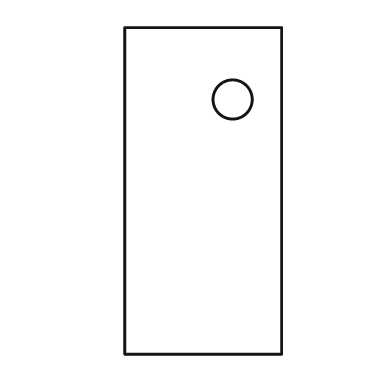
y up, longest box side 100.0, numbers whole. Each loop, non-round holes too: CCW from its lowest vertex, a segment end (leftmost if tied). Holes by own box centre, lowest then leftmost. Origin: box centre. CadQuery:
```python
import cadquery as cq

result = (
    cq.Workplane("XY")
    .moveTo(-24.0, -50.0)
    .lineTo(24.0, -50.0)
    .lineTo(24.0, 50.0)
    .lineTo(-24.0, 50.0)
    .close()
    .moveTo(9.0, 28.0)
    .circle(6.0)
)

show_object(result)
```